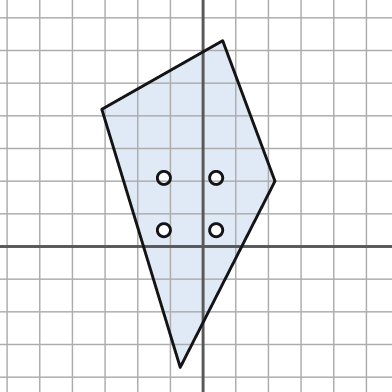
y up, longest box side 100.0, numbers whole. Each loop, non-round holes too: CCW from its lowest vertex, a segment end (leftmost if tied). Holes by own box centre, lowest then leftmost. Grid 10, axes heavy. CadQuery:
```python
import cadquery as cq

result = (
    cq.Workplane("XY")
    .moveTo(-7.0, -37.0)
    .lineTo(22.0, 20.0)
    .lineTo(6.0, 63.0)
    .lineTo(-31.0, 42.0)
    .close()
    .moveTo(-12.0, 5.0)
    .circle(2.0)
    .moveTo(4.0, 5.0)
    .circle(2.0)
    .moveTo(-12.0, 21.0)
    .circle(2.0)
    .moveTo(4.0, 21.0)
    .circle(2.0)
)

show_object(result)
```